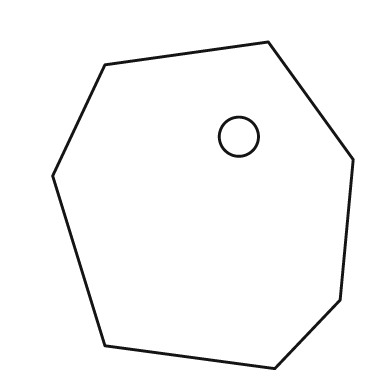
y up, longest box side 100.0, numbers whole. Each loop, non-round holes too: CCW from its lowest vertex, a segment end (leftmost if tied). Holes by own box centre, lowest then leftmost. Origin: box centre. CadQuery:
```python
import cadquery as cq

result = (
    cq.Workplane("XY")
    .moveTo(22.0, -50.0)
    .lineTo(42.0, -29.0)
    .lineTo(46.0, 14.0)
    .lineTo(20.0, 50.0)
    .lineTo(-30.0, 43.0)
    .lineTo(-46.0, 9.0)
    .lineTo(-30.0, -43.0)
    .close()
    .moveTo(11.0, 21.0)
    .circle(6.0)
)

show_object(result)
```